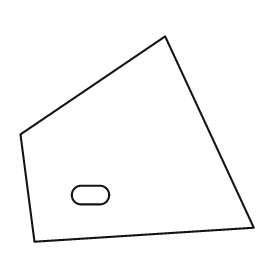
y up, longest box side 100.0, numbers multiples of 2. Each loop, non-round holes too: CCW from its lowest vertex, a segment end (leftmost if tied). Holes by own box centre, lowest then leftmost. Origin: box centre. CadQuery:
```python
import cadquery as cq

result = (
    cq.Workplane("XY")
    .moveTo(-44.0, -44.0)
    .lineTo(50.0, -38.0)
    .lineTo(12.0, 44.0)
    .lineTo(-50.0, 2.0)
    .close()
    .moveTo(-24.0, -28.0)
    .lineTo(-16.0, -28.0)
    .threePointArc((-12.0, -24.0), (-16.0, -20.0))
    .lineTo(-24.0, -20.0)
    .threePointArc((-28.0, -24.0), (-24.0, -28.0))
    .close()
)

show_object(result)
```